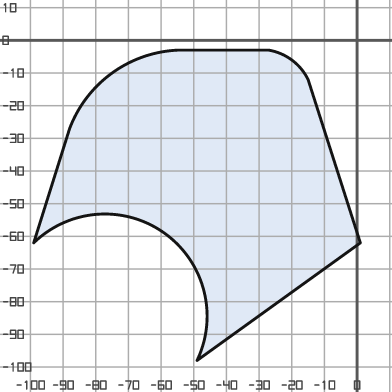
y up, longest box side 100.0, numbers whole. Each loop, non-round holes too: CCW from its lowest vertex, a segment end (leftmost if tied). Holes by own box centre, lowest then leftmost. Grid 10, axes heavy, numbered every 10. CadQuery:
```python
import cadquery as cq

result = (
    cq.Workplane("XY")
    .moveTo(-49.0, -98.0)
    .lineTo(1.0, -62.0)
    .lineTo(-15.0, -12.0)
    .threePointArc((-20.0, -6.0), (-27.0, -3.0))
    .lineTo(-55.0, -3.0)
    .threePointArc((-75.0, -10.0), (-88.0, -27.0))
    .lineTo(-99.0, -62.0)
    .threePointArc((-59.0, -59.0), (-49.0, -98.0))
    .close()
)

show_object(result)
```